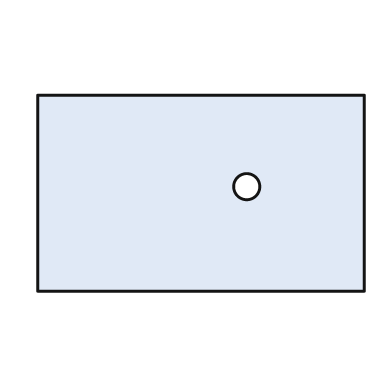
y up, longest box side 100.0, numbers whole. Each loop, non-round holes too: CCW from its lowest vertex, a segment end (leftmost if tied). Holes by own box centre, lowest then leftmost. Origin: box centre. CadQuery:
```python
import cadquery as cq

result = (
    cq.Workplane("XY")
    .moveTo(-50.0, -30.0)
    .lineTo(50.0, -30.0)
    .lineTo(50.0, 30.0)
    .lineTo(-50.0, 30.0)
    .close()
    .moveTo(14.0, 2.0)
    .circle(4.0)
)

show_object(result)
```